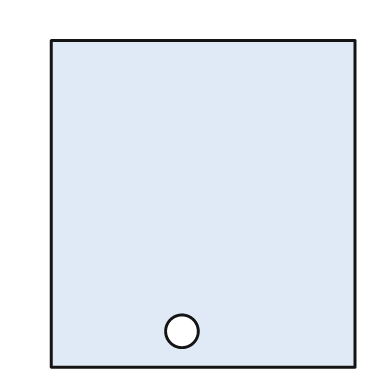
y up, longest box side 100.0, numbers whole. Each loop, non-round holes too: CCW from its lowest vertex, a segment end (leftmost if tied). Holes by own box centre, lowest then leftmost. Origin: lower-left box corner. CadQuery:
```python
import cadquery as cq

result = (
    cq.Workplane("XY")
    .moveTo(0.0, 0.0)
    .lineTo(93.0, 0.0)
    .lineTo(93.0, 100.0)
    .lineTo(0.0, 100.0)
    .close()
    .moveTo(40.0, 11.0)
    .circle(5.0)
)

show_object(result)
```